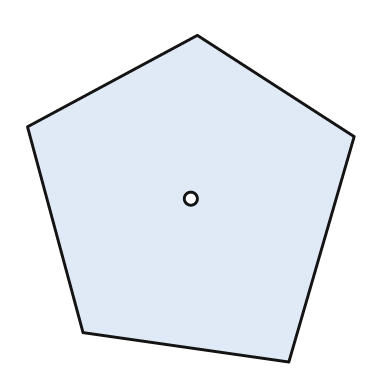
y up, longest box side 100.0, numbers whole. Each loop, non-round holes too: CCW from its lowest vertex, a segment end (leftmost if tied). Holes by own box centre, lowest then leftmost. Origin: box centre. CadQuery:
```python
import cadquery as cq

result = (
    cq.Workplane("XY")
    .moveTo(30.0, -50.0)
    .lineTo(50.0, 19.0)
    .lineTo(2.0, 50.0)
    .lineTo(-50.0, 22.0)
    .lineTo(-33.0, -41.0)
    .close()
    .moveTo(0.0, 0.0)
    .circle(2.0)
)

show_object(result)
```